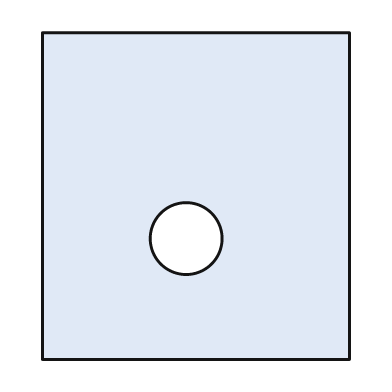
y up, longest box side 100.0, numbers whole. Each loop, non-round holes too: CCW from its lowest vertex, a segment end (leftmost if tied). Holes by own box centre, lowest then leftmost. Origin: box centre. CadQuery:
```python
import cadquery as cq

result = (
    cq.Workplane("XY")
    .moveTo(-47.0, -50.0)
    .lineTo(47.0, -50.0)
    .lineTo(47.0, 50.0)
    .lineTo(-47.0, 50.0)
    .close()
    .moveTo(-3.0, -13.0)
    .circle(11.0)
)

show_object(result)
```